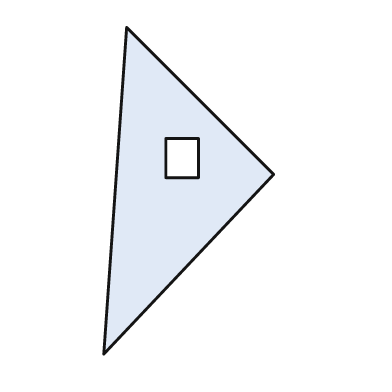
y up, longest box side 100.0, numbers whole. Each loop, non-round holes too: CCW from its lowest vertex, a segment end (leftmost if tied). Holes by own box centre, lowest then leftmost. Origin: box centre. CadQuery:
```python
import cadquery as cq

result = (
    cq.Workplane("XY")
    .moveTo(-26.0, -50.0)
    .lineTo(26.0, 5.0)
    .lineTo(-19.0, 50.0)
    .close()
    .moveTo(-7.0, 4.0)
    .lineTo(3.0, 4.0)
    .lineTo(3.0, 16.0)
    .lineTo(-7.0, 16.0)
    .close()
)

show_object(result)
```